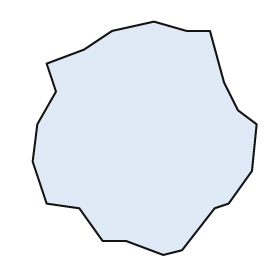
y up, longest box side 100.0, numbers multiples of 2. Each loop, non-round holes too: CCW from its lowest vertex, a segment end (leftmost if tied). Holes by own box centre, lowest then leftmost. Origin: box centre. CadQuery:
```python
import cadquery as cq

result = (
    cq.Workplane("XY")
    .moveTo(8.0, -50.0)
    .lineTo(16.0, -48.0)
    .lineTo(30.0, -30.0)
    .lineTo(36.0, -28.0)
    .lineTo(46.0, -14.0)
    .lineTo(48.0, 6.0)
    .lineTo(40.0, 12.0)
    .lineTo(34.0, 24.0)
    .lineTo(28.0, 46.0)
    .lineTo(18.0, 46.0)
    .lineTo(4.0, 50.0)
    .lineTo(-14.0, 46.0)
    .lineTo(-26.0, 38.0)
    .lineTo(-42.0, 32.0)
    .lineTo(-38.0, 20.0)
    .lineTo(-46.0, 6.0)
    .lineTo(-48.0, -10.0)
    .lineTo(-42.0, -28.0)
    .lineTo(-28.0, -30.0)
    .lineTo(-18.0, -44.0)
    .lineTo(-8.0, -44.0)
    .close()
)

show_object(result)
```